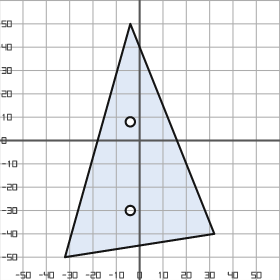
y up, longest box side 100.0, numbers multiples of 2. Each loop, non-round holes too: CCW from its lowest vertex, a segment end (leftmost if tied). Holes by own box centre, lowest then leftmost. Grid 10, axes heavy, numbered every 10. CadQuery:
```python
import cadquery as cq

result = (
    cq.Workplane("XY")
    .moveTo(-32.0, -50.0)
    .lineTo(32.0, -40.0)
    .lineTo(-4.0, 50.0)
    .close()
    .moveTo(-4.0, -30.0)
    .circle(2.0)
    .moveTo(-4.0, 8.0)
    .circle(2.0)
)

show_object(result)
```